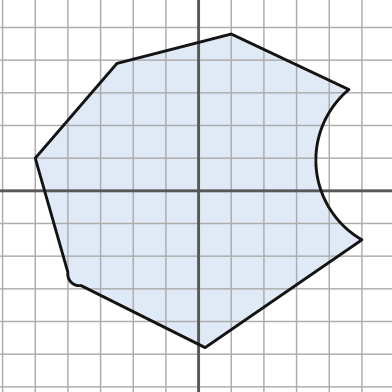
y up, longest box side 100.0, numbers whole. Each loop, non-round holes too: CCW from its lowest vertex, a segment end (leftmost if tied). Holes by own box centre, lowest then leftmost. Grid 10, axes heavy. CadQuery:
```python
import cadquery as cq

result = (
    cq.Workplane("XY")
    .moveTo(2.0, -48.0)
    .lineTo(50.0, -15.0)
    .threePointArc((36.0, 7.0), (46.0, 31.0))
    .lineTo(10.0, 48.0)
    .lineTo(-25.0, 39.0)
    .lineTo(-50.0, 10.0)
    .lineTo(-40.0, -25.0)
    .threePointArc((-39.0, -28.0), (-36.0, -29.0))
    .close()
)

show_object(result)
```